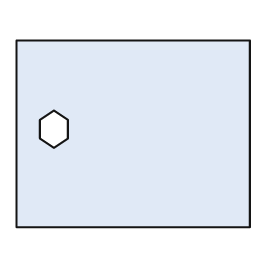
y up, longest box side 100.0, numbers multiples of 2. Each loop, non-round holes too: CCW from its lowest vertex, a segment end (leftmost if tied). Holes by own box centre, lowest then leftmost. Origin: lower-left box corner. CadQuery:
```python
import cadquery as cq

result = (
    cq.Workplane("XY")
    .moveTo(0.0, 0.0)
    .lineTo(100.0, 0.0)
    .lineTo(100.0, 80.0)
    .lineTo(0.0, 80.0)
    .close()
    .moveTo(16.0, 34.0)
    .lineTo(22.0, 38.0)
    .lineTo(22.0, 46.0)
    .lineTo(16.0, 50.0)
    .lineTo(10.0, 46.0)
    .lineTo(10.0, 38.0)
    .close()
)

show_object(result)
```